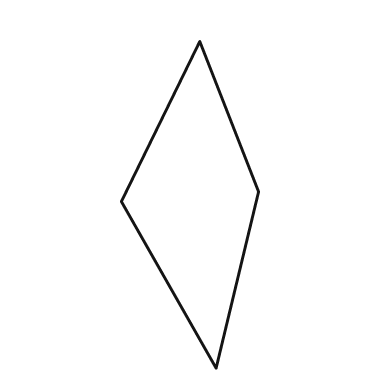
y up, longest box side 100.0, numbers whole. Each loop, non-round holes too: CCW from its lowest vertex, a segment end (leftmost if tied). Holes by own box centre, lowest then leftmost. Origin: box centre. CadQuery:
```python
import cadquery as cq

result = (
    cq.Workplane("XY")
    .moveTo(8.0, -50.0)
    .lineTo(21.0, 4.0)
    .lineTo(3.0, 50.0)
    .lineTo(-21.0, 1.0)
    .close()
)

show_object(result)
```